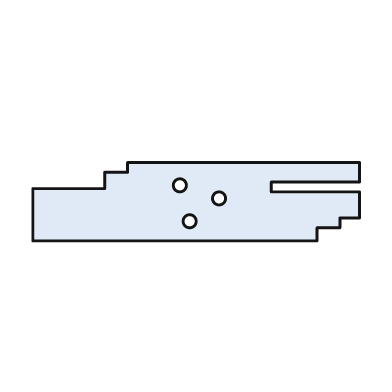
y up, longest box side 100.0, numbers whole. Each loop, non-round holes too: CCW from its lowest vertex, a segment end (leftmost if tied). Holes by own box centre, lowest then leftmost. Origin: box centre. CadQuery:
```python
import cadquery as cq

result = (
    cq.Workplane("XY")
    .moveTo(-50.0, -12.0)
    .lineTo(37.0, -12.0)
    .lineTo(37.0, -8.0)
    .lineTo(44.0, -8.0)
    .lineTo(44.0, -5.0)
    .lineTo(50.0, -5.0)
    .lineTo(50.0, 3.0)
    .lineTo(23.0, 3.0)
    .lineTo(23.0, 6.0)
    .lineTo(50.0, 6.0)
    .lineTo(50.0, 12.0)
    .lineTo(-21.0, 12.0)
    .lineTo(-21.0, 9.0)
    .lineTo(-28.0, 9.0)
    .lineTo(-28.0, 4.0)
    .lineTo(-50.0, 4.0)
    .close()
    .moveTo(-2.0, -6.0)
    .circle(2.0)
    .moveTo(7.0, 1.0)
    .circle(2.0)
    .moveTo(-5.0, 5.0)
    .circle(2.0)
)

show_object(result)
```